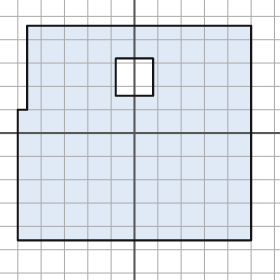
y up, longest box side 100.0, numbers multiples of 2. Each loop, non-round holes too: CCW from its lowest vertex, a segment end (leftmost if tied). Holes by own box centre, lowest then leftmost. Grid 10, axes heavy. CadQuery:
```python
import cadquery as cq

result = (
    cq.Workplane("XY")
    .moveTo(-50.0, -46.0)
    .lineTo(50.0, -46.0)
    .lineTo(50.0, 46.0)
    .lineTo(-46.0, 46.0)
    .lineTo(-46.0, 10.0)
    .lineTo(-50.0, 10.0)
    .close()
    .moveTo(-8.0, 16.0)
    .lineTo(8.0, 16.0)
    .lineTo(8.0, 32.0)
    .lineTo(-8.0, 32.0)
    .close()
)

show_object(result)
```